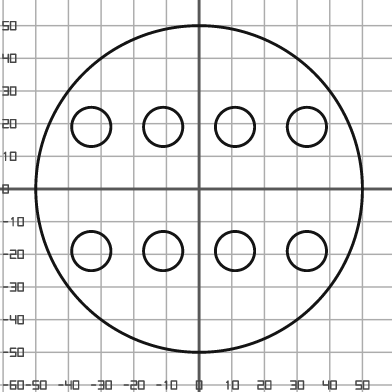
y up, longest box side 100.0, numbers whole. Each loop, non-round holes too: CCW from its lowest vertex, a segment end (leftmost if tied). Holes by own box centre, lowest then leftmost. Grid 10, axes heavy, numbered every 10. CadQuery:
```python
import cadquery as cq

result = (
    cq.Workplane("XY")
    .moveTo(0.0, 0.0)
    .circle(50.0)
    .moveTo(-33.0, -19.0)
    .circle(6.0)
    .moveTo(-11.0, -19.0)
    .circle(6.0)
    .moveTo(11.0, -19.0)
    .circle(6.0)
    .moveTo(33.0, -19.0)
    .circle(6.0)
    .moveTo(-33.0, 19.0)
    .circle(6.0)
    .moveTo(-11.0, 19.0)
    .circle(6.0)
    .moveTo(11.0, 19.0)
    .circle(6.0)
    .moveTo(33.0, 19.0)
    .circle(6.0)
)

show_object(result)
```